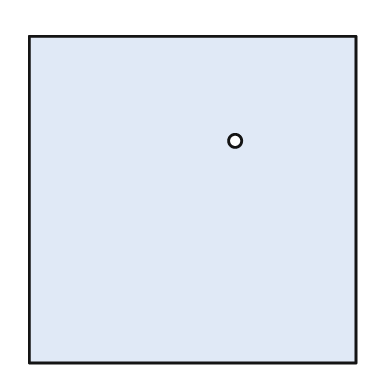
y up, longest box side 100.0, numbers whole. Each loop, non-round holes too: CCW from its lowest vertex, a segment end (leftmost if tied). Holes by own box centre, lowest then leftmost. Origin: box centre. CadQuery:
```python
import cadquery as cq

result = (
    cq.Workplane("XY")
    .moveTo(-50.0, -50.0)
    .lineTo(50.0, -50.0)
    .lineTo(50.0, 50.0)
    .lineTo(-50.0, 50.0)
    .close()
    .moveTo(13.0, 18.0)
    .circle(2.0)
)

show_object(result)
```